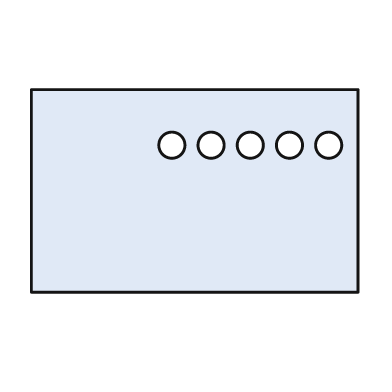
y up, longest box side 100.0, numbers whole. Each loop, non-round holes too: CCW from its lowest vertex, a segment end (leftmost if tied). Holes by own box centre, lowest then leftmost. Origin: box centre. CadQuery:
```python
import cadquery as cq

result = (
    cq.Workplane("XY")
    .moveTo(-50.0, -31.0)
    .lineTo(50.0, -31.0)
    .lineTo(50.0, 31.0)
    .lineTo(-50.0, 31.0)
    .close()
    .moveTo(-7.0, 14.0)
    .circle(4.0)
    .moveTo(5.0, 14.0)
    .circle(4.0)
    .moveTo(17.0, 14.0)
    .circle(4.0)
    .moveTo(29.0, 14.0)
    .circle(4.0)
    .moveTo(41.0, 14.0)
    .circle(4.0)
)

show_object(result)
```